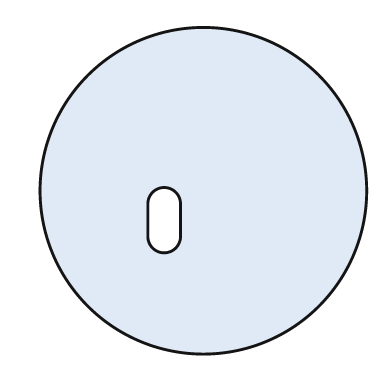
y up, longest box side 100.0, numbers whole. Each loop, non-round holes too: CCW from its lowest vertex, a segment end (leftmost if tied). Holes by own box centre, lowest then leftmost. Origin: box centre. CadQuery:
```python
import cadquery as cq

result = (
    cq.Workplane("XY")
    .moveTo(0.0, 0.0)
    .circle(50.0)
    .moveTo(-17.0, -14.0)
    .threePointArc((-12.0, -19.0), (-7.0, -14.0))
    .lineTo(-7.0, -4.0)
    .threePointArc((-12.0, 1.0), (-17.0, -4.0))
    .close()
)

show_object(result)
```